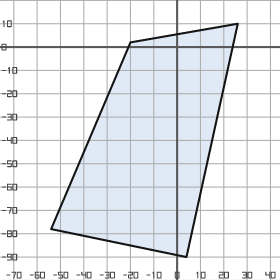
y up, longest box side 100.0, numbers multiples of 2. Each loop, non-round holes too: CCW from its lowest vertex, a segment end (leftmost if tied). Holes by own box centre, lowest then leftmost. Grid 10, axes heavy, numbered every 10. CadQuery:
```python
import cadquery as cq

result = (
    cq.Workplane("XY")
    .moveTo(4.0, -90.0)
    .lineTo(26.0, 10.0)
    .lineTo(-20.0, 2.0)
    .lineTo(-54.0, -78.0)
    .close()
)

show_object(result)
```